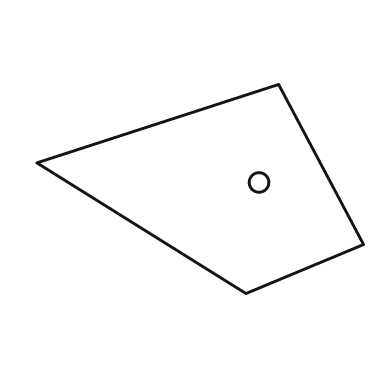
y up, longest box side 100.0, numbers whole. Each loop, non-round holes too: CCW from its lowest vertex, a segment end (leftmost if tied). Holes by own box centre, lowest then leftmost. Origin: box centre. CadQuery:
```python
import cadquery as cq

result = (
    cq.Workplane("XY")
    .moveTo(14.0, -32.0)
    .lineTo(50.0, -17.0)
    .lineTo(24.0, 32.0)
    .lineTo(-50.0, 8.0)
    .close()
    .moveTo(18.0, 2.0)
    .circle(3.0)
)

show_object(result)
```